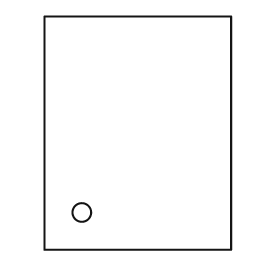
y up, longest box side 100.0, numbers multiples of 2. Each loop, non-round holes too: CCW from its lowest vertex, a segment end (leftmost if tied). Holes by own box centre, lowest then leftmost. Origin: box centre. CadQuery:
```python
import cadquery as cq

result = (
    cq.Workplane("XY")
    .moveTo(-40.0, -50.0)
    .lineTo(40.0, -50.0)
    .lineTo(40.0, 50.0)
    .lineTo(-40.0, 50.0)
    .close()
    .moveTo(-24.0, -34.0)
    .circle(4.0)
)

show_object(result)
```